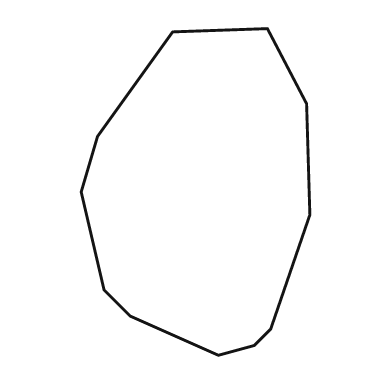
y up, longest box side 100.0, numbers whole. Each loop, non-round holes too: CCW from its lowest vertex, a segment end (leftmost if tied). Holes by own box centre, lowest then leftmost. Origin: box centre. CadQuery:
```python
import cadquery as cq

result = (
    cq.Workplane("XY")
    .moveTo(7.0, -50.0)
    .lineTo(18.0, -47.0)
    .lineTo(23.0, -42.0)
    .lineTo(35.0, -7.0)
    .lineTo(34.0, 27.0)
    .lineTo(22.0, 50.0)
    .lineTo(-7.0, 49.0)
    .lineTo(-30.0, 17.0)
    .lineTo(-35.0, 0.0)
    .lineTo(-28.0, -30.0)
    .lineTo(-20.0, -38.0)
    .close()
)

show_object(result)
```